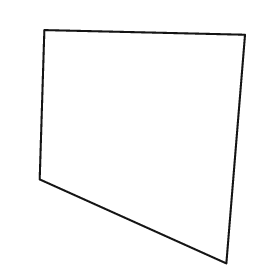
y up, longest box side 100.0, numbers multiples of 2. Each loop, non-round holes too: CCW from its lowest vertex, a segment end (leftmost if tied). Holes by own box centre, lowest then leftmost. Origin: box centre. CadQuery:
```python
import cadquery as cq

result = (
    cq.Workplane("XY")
    .moveTo(36.0, -50.0)
    .lineTo(44.0, 48.0)
    .lineTo(-42.0, 50.0)
    .lineTo(-44.0, -14.0)
    .close()
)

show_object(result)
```